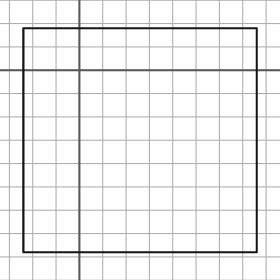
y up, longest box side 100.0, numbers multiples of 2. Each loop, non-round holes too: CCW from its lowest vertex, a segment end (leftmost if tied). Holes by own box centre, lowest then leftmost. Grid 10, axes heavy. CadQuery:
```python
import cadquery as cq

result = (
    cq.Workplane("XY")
    .moveTo(-24.0, -78.0)
    .lineTo(76.0, -78.0)
    .lineTo(76.0, 18.0)
    .lineTo(-24.0, 18.0)
    .close()
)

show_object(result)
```